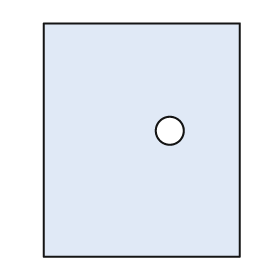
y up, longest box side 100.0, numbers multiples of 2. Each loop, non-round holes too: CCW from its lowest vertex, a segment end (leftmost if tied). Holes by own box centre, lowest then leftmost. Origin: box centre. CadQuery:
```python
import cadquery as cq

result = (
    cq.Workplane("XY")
    .moveTo(-42.0, -50.0)
    .lineTo(42.0, -50.0)
    .lineTo(42.0, 50.0)
    .lineTo(-42.0, 50.0)
    .close()
    .moveTo(12.0, 4.0)
    .circle(6.0)
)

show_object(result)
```